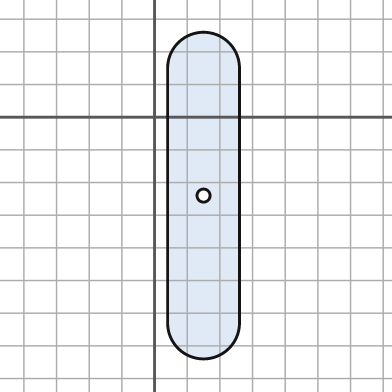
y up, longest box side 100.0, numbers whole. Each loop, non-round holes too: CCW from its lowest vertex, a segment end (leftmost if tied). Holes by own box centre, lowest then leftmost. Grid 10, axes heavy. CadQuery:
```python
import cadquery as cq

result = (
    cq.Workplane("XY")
    .moveTo(4.0, -63.0)
    .threePointArc((15.0, -74.0), (26.0, -63.0))
    .lineTo(26.0, 15.0)
    .threePointArc((15.0, 26.0), (4.0, 15.0))
    .close()
    .moveTo(15.0, -24.0)
    .circle(2.0)
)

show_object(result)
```